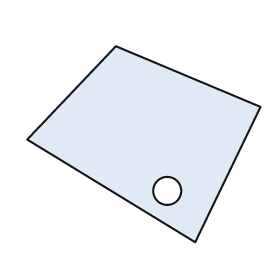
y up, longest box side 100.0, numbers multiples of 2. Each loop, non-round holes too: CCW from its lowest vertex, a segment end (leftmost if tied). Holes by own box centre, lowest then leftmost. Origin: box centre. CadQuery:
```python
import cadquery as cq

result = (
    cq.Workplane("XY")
    .moveTo(22.0, -42.0)
    .lineTo(50.0, 16.0)
    .lineTo(-12.0, 42.0)
    .lineTo(-50.0, 2.0)
    .close()
    .moveTo(10.0, -20.0)
    .circle(6.0)
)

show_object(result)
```